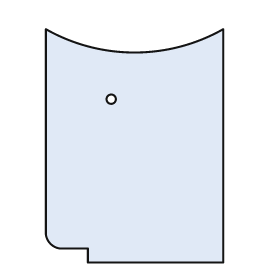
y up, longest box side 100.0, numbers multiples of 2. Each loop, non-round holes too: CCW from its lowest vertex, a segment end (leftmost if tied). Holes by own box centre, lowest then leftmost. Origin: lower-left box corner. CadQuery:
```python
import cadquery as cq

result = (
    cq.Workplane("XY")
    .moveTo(18.0, 0.0)
    .lineTo(76.0, 0.0)
    .lineTo(76.0, 100.0)
    .threePointArc((38.0, 90.0), (0.0, 100.0))
    .lineTo(0.0, 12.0)
    .threePointArc((2.0, 8.0), (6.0, 6.0))
    .lineTo(18.0, 6.0)
    .close()
    .moveTo(28.0, 70.0)
    .circle(2.0)
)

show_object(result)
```